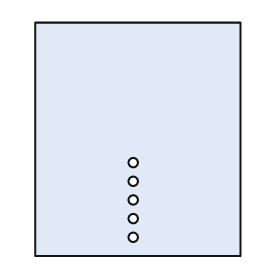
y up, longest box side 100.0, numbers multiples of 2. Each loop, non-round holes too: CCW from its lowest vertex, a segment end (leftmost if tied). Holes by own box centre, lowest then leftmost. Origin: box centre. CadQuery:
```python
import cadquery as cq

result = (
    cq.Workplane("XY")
    .moveTo(-44.0, -50.0)
    .lineTo(44.0, -50.0)
    .lineTo(44.0, 50.0)
    .lineTo(-44.0, 50.0)
    .close()
    .moveTo(-2.0, -42.0)
    .circle(2.0)
    .moveTo(-2.0, -34.0)
    .circle(2.0)
    .moveTo(-2.0, -26.0)
    .circle(2.0)
    .moveTo(-2.0, -18.0)
    .circle(2.0)
    .moveTo(-2.0, -10.0)
    .circle(2.0)
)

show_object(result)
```